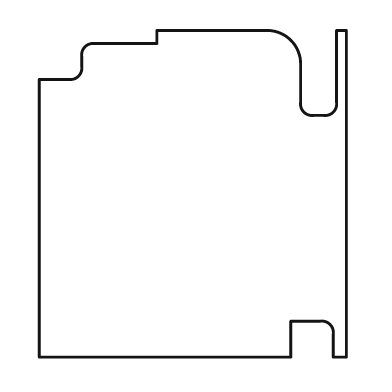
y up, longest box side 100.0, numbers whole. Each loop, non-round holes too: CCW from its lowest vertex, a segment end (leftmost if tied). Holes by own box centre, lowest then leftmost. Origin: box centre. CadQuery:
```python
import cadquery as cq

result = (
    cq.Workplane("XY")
    .moveTo(-47.0, -50.0)
    .lineTo(30.0, -50.0)
    .lineTo(30.0, -39.0)
    .lineTo(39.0, -39.0)
    .threePointArc((42.0, -40.0), (43.0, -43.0))
    .lineTo(43.0, -50.0)
    .lineTo(47.0, -50.0)
    .lineTo(47.0, 50.0)
    .lineTo(44.0, 50.0)
    .lineTo(44.0, 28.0)
    .threePointArc((43.0, 25.0), (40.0, 24.0))
    .lineTo(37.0, 24.0)
    .threePointArc((34.0, 25.0), (33.0, 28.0))
    .lineTo(33.0, 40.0)
    .threePointArc((30.0, 47.0), (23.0, 50.0))
    .lineTo(-11.0, 50.0)
    .lineTo(-11.0, 46.0)
    .lineTo(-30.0, 46.0)
    .threePointArc((-33.0, 45.0), (-34.0, 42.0))
    .lineTo(-34.0, 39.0)
    .threePointArc((-35.0, 36.0), (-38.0, 35.0))
    .lineTo(-47.0, 35.0)
    .close()
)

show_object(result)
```